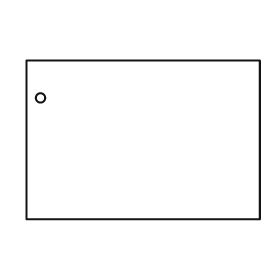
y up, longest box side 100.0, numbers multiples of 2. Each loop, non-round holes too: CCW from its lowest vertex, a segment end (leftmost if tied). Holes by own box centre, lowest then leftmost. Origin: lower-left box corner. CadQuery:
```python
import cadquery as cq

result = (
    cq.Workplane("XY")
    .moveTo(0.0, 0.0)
    .lineTo(100.0, 0.0)
    .lineTo(100.0, 68.0)
    .lineTo(0.0, 68.0)
    .close()
    .moveTo(6.0, 52.0)
    .circle(2.0)
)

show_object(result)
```